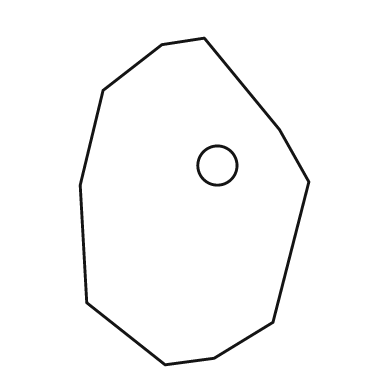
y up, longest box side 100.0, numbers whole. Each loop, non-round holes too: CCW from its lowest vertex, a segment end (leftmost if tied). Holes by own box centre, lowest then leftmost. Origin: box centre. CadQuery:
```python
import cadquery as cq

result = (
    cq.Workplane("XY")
    .moveTo(-9.0, -50.0)
    .lineTo(6.0, -48.0)
    .lineTo(24.0, -37.0)
    .lineTo(35.0, 6.0)
    .lineTo(26.0, 22.0)
    .lineTo(3.0, 50.0)
    .lineTo(-10.0, 48.0)
    .lineTo(-28.0, 34.0)
    .lineTo(-35.0, 5.0)
    .lineTo(-33.0, -31.0)
    .close()
    .moveTo(7.0, 11.0)
    .circle(6.0)
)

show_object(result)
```